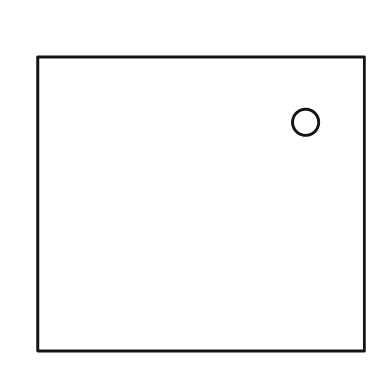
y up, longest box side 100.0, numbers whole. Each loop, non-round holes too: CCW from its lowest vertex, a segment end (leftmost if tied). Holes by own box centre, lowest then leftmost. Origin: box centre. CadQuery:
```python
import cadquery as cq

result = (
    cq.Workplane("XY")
    .moveTo(-50.0, -45.0)
    .lineTo(50.0, -45.0)
    .lineTo(50.0, 45.0)
    .lineTo(-50.0, 45.0)
    .close()
    .moveTo(32.0, 25.0)
    .circle(4.0)
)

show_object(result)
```